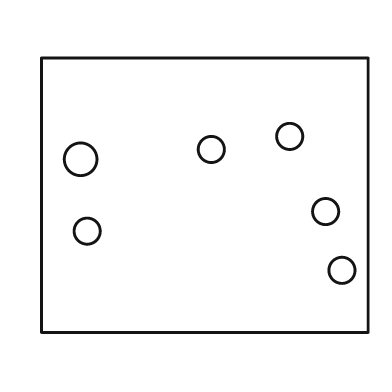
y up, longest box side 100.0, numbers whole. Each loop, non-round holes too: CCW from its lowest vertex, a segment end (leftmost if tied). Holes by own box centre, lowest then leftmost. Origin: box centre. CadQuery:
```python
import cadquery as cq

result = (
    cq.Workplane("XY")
    .moveTo(-50.0, -42.0)
    .lineTo(50.0, -42.0)
    .lineTo(50.0, 42.0)
    .lineTo(-50.0, 42.0)
    .close()
    .moveTo(42.0, -23.0)
    .circle(4.0)
    .moveTo(-36.0, -11.0)
    .circle(4.0)
    .moveTo(37.0, -5.0)
    .circle(4.0)
    .moveTo(-38.0, 11.0)
    .circle(5.0)
    .moveTo(2.0, 14.0)
    .circle(4.0)
    .moveTo(26.0, 18.0)
    .circle(4.0)
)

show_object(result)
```